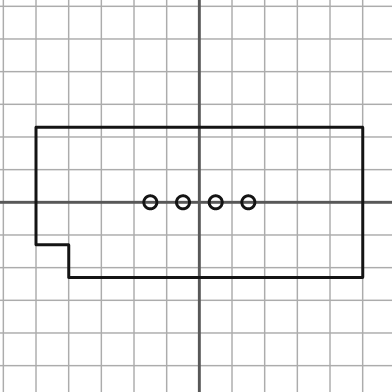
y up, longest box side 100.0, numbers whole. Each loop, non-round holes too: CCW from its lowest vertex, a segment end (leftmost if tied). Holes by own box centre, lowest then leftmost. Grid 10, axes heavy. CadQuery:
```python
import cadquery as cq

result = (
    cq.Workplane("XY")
    .moveTo(-40.0, -23.0)
    .lineTo(50.0, -23.0)
    .lineTo(50.0, 23.0)
    .lineTo(-50.0, 23.0)
    .lineTo(-50.0, -13.0)
    .lineTo(-40.0, -13.0)
    .close()
    .moveTo(-15.0, 0.0)
    .circle(2.0)
    .moveTo(-5.0, 0.0)
    .circle(2.0)
    .moveTo(5.0, 0.0)
    .circle(2.0)
    .moveTo(15.0, 0.0)
    .circle(2.0)
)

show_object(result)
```